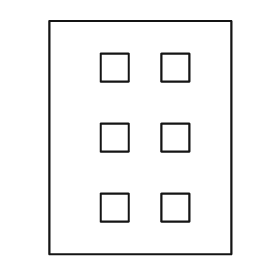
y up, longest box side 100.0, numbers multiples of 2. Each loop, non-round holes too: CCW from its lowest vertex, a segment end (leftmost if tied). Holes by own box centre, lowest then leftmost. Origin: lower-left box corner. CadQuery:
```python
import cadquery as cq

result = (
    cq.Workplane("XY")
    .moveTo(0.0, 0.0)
    .lineTo(78.0, 0.0)
    .lineTo(78.0, 100.0)
    .lineTo(0.0, 100.0)
    .close()
    .moveTo(22.0, 14.0)
    .lineTo(34.0, 14.0)
    .lineTo(34.0, 26.0)
    .lineTo(22.0, 26.0)
    .close()
    .moveTo(48.0, 14.0)
    .lineTo(60.0, 14.0)
    .lineTo(60.0, 26.0)
    .lineTo(48.0, 26.0)
    .close()
    .moveTo(22.0, 44.0)
    .lineTo(34.0, 44.0)
    .lineTo(34.0, 56.0)
    .lineTo(22.0, 56.0)
    .close()
    .moveTo(48.0, 44.0)
    .lineTo(60.0, 44.0)
    .lineTo(60.0, 56.0)
    .lineTo(48.0, 56.0)
    .close()
    .moveTo(22.0, 74.0)
    .lineTo(34.0, 74.0)
    .lineTo(34.0, 86.0)
    .lineTo(22.0, 86.0)
    .close()
    .moveTo(48.0, 74.0)
    .lineTo(60.0, 74.0)
    .lineTo(60.0, 86.0)
    .lineTo(48.0, 86.0)
    .close()
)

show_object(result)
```